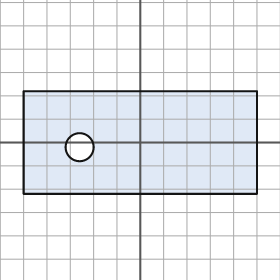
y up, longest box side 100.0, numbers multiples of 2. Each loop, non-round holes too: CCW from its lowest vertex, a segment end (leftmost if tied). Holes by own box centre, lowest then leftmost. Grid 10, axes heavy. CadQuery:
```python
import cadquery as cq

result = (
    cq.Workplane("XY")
    .moveTo(-50.0, -22.0)
    .lineTo(50.0, -22.0)
    .lineTo(50.0, 22.0)
    .lineTo(-50.0, 22.0)
    .close()
    .moveTo(-26.0, -2.0)
    .circle(6.0)
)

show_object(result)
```